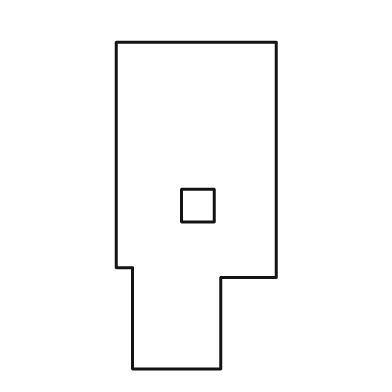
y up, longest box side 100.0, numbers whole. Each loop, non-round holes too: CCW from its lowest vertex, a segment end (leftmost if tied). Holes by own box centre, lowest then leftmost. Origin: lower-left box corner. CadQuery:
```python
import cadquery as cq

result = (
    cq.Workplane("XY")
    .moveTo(5.0, 0.0)
    .lineTo(32.0, 0.0)
    .lineTo(32.0, 28.0)
    .lineTo(49.0, 28.0)
    .lineTo(49.0, 100.0)
    .lineTo(0.0, 100.0)
    .lineTo(0.0, 31.0)
    .lineTo(5.0, 31.0)
    .close()
    .moveTo(20.0, 45.0)
    .lineTo(30.0, 45.0)
    .lineTo(30.0, 55.0)
    .lineTo(20.0, 55.0)
    .close()
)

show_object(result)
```